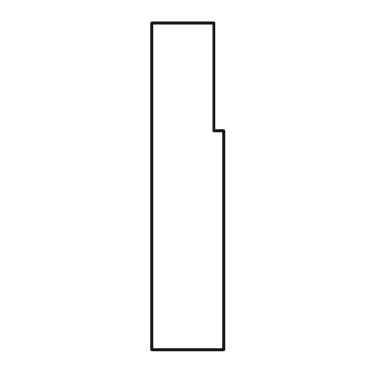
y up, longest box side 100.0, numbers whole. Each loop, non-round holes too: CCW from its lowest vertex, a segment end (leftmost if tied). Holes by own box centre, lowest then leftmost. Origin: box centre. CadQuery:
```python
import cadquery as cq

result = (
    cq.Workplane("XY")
    .moveTo(-11.0, -50.0)
    .lineTo(11.0, -50.0)
    .lineTo(11.0, 17.0)
    .lineTo(8.0, 17.0)
    .lineTo(8.0, 50.0)
    .lineTo(-11.0, 50.0)
    .close()
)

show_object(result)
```